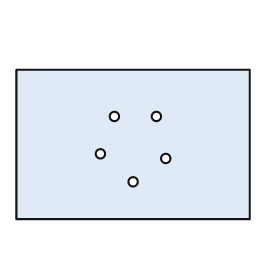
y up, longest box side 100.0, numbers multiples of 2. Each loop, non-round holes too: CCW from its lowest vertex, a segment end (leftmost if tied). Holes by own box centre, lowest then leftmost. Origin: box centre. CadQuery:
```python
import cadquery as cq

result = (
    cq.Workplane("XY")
    .moveTo(-50.0, -32.0)
    .lineTo(50.0, -32.0)
    .lineTo(50.0, 32.0)
    .lineTo(-50.0, 32.0)
    .close()
    .moveTo(0.0, -16.0)
    .circle(2.0)
    .moveTo(14.0, -6.0)
    .circle(2.0)
    .moveTo(-14.0, -4.0)
    .circle(2.0)
    .moveTo(-8.0, 12.0)
    .circle(2.0)
    .moveTo(10.0, 12.0)
    .circle(2.0)
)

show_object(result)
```